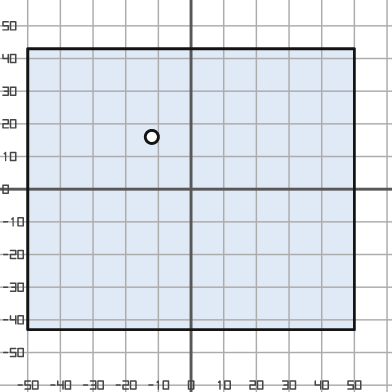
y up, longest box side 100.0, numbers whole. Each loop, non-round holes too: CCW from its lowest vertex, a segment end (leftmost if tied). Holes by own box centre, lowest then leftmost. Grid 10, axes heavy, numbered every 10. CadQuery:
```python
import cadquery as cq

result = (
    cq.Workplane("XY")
    .moveTo(-50.0, -43.0)
    .lineTo(50.0, -43.0)
    .lineTo(50.0, 43.0)
    .lineTo(-50.0, 43.0)
    .close()
    .moveTo(-12.0, 16.0)
    .circle(2.0)
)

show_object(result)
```